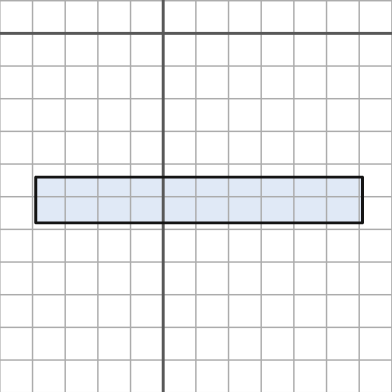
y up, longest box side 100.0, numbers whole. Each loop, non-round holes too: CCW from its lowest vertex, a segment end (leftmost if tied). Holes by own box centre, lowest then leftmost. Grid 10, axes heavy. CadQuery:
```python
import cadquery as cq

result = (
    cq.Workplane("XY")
    .moveTo(-39.0, -58.0)
    .lineTo(61.0, -58.0)
    .lineTo(61.0, -44.0)
    .lineTo(-39.0, -44.0)
    .close()
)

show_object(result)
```